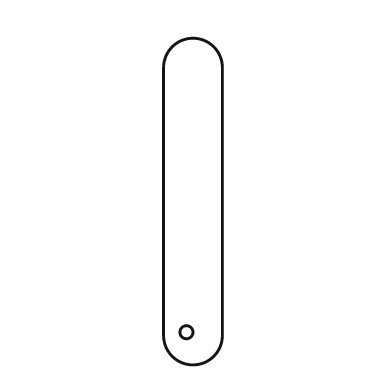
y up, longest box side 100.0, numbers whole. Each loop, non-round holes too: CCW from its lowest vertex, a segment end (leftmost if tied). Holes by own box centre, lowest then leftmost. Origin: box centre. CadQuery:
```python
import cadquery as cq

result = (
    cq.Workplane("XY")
    .moveTo(-9.0, -41.0)
    .threePointArc((0.0, -50.0), (9.0, -41.0))
    .lineTo(9.0, 41.0)
    .threePointArc((0.0, 50.0), (-9.0, 41.0))
    .close()
    .moveTo(-2.0, -40.0)
    .circle(2.0)
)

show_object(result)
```